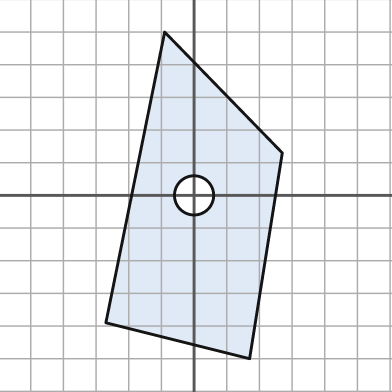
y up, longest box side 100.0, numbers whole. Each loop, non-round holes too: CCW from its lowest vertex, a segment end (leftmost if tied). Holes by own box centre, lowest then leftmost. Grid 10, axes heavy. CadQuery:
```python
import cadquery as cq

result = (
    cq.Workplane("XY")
    .moveTo(17.0, -50.0)
    .lineTo(27.0, 13.0)
    .lineTo(-9.0, 50.0)
    .lineTo(-27.0, -39.0)
    .close()
    .moveTo(0.0, 0.0)
    .circle(6.0)
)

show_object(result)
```